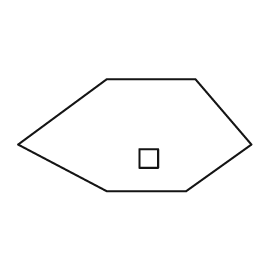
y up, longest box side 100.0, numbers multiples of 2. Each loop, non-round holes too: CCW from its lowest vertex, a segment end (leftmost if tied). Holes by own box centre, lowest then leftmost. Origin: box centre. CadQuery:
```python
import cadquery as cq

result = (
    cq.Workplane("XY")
    .moveTo(-12.0, -24.0)
    .lineTo(22.0, -24.0)
    .lineTo(50.0, -4.0)
    .lineTo(26.0, 24.0)
    .lineTo(-12.0, 24.0)
    .lineTo(-50.0, -4.0)
    .close()
    .moveTo(2.0, -14.0)
    .lineTo(10.0, -14.0)
    .lineTo(10.0, -6.0)
    .lineTo(2.0, -6.0)
    .close()
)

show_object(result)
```